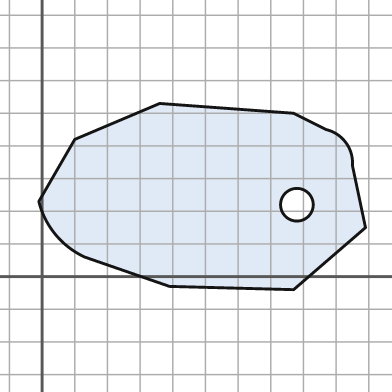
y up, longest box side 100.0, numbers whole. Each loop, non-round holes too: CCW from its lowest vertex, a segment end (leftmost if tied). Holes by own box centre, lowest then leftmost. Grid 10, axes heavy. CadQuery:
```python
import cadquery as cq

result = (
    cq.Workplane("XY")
    .moveTo(77.0, -4.0)
    .lineTo(99.0, 15.0)
    .lineTo(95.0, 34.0)
    .threePointArc((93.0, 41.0), (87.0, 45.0))
    .lineTo(77.0, 50.0)
    .lineTo(36.0, 53.0)
    .lineTo(10.0, 42.0)
    .lineTo(-1.0, 23.0)
    .threePointArc((4.0, 13.0), (13.0, 6.0))
    .lineTo(39.0, -3.0)
    .close()
    .moveTo(78.0, 22.0)
    .circle(5.0)
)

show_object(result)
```